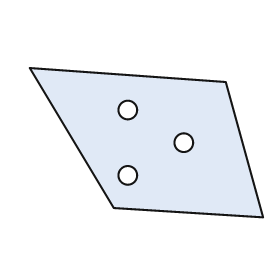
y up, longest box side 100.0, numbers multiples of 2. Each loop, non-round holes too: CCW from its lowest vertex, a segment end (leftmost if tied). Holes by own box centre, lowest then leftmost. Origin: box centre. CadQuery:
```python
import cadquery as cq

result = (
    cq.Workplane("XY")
    .moveTo(50.0, -32.0)
    .lineTo(34.0, 26.0)
    .lineTo(-50.0, 32.0)
    .lineTo(-14.0, -28.0)
    .close()
    .moveTo(-8.0, -14.0)
    .circle(4.0)
    .moveTo(16.0, 0.0)
    .circle(4.0)
    .moveTo(-8.0, 14.0)
    .circle(4.0)
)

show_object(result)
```